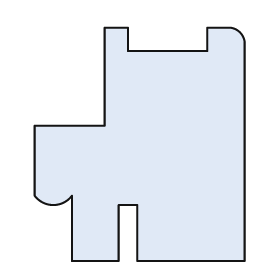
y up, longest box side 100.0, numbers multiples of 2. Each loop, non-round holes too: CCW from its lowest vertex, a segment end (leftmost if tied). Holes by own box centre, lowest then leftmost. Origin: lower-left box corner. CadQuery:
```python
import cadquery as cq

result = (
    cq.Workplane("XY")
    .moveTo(16.0, 0.0)
    .lineTo(36.0, 0.0)
    .lineTo(36.0, 24.0)
    .lineTo(44.0, 24.0)
    .lineTo(44.0, 0.0)
    .lineTo(90.0, 0.0)
    .lineTo(90.0, 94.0)
    .threePointArc((88.0, 98.0), (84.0, 100.0))
    .lineTo(74.0, 100.0)
    .lineTo(74.0, 90.0)
    .lineTo(40.0, 90.0)
    .lineTo(40.0, 100.0)
    .lineTo(30.0, 100.0)
    .lineTo(30.0, 58.0)
    .lineTo(0.0, 58.0)
    .lineTo(0.0, 28.0)
    .threePointArc((8.0, 24.0), (16.0, 28.0))
    .close()
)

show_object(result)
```